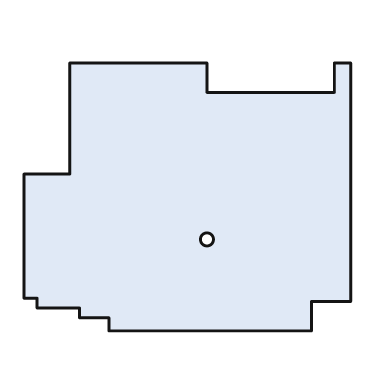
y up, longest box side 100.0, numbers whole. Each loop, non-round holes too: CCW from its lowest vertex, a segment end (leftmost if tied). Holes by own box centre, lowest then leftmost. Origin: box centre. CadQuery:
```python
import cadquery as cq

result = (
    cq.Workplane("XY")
    .moveTo(-24.0, -41.0)
    .lineTo(38.0, -41.0)
    .lineTo(38.0, -32.0)
    .lineTo(50.0, -32.0)
    .lineTo(50.0, 41.0)
    .lineTo(45.0, 41.0)
    .lineTo(45.0, 32.0)
    .lineTo(6.0, 32.0)
    .lineTo(6.0, 41.0)
    .lineTo(-36.0, 41.0)
    .lineTo(-36.0, 7.0)
    .lineTo(-50.0, 7.0)
    .lineTo(-50.0, -31.0)
    .lineTo(-46.0, -31.0)
    .lineTo(-46.0, -34.0)
    .lineTo(-33.0, -34.0)
    .lineTo(-33.0, -37.0)
    .lineTo(-24.0, -37.0)
    .close()
    .moveTo(6.0, -13.0)
    .circle(2.0)
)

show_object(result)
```